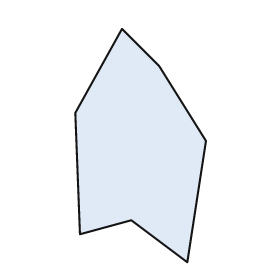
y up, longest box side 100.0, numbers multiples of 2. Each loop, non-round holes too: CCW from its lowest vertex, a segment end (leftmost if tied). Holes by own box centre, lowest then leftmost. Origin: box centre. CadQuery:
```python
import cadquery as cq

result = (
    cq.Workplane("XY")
    .moveTo(20.0, -50.0)
    .lineTo(28.0, 2.0)
    .lineTo(8.0, 34.0)
    .lineTo(-8.0, 50.0)
    .lineTo(-28.0, 14.0)
    .lineTo(-26.0, -38.0)
    .lineTo(-4.0, -32.0)
    .close()
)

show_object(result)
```